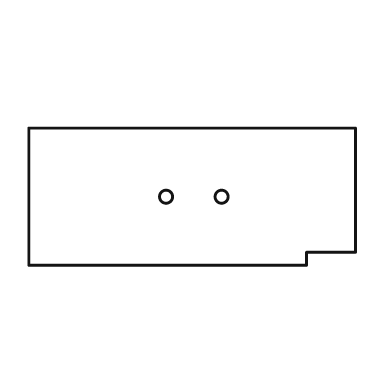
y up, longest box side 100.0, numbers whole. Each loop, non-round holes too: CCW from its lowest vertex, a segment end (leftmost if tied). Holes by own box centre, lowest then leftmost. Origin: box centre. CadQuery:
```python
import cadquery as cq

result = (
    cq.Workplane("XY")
    .moveTo(-50.0, -21.0)
    .lineTo(35.0, -21.0)
    .lineTo(35.0, -17.0)
    .lineTo(50.0, -17.0)
    .lineTo(50.0, 21.0)
    .lineTo(-50.0, 21.0)
    .close()
    .moveTo(-8.0, 0.0)
    .circle(2.0)
    .moveTo(9.0, 0.0)
    .circle(2.0)
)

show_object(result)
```